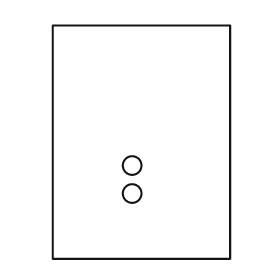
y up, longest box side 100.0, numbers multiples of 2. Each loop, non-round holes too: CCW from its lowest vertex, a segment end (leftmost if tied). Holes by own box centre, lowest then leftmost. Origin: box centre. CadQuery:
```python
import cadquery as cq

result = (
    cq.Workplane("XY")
    .moveTo(-38.0, -50.0)
    .lineTo(38.0, -50.0)
    .lineTo(38.0, 50.0)
    .lineTo(-38.0, 50.0)
    .close()
    .moveTo(-4.0, -22.0)
    .circle(4.0)
    .moveTo(-4.0, -10.0)
    .circle(4.0)
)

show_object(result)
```